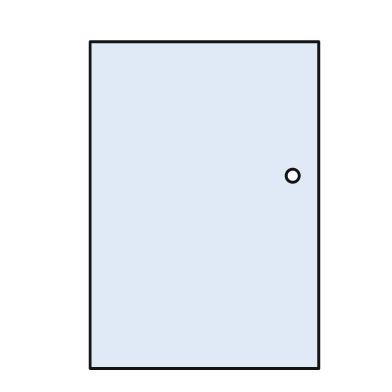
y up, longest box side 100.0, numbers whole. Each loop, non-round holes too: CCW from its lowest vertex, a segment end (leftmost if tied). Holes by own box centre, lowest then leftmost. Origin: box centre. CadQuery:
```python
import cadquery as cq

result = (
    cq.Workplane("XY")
    .moveTo(-35.0, -50.0)
    .lineTo(35.0, -50.0)
    .lineTo(35.0, 50.0)
    .lineTo(-35.0, 50.0)
    .close()
    .moveTo(27.0, 9.0)
    .circle(2.0)
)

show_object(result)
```